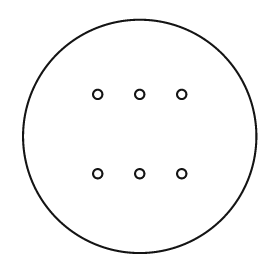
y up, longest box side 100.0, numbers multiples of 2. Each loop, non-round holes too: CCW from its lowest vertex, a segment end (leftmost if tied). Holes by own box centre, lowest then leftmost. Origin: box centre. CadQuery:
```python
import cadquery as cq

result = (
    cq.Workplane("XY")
    .moveTo(0.0, 0.0)
    .circle(50.0)
    .moveTo(-18.0, -16.0)
    .circle(2.0)
    .moveTo(0.0, -16.0)
    .circle(2.0)
    .moveTo(18.0, -16.0)
    .circle(2.0)
    .moveTo(-18.0, 18.0)
    .circle(2.0)
    .moveTo(0.0, 18.0)
    .circle(2.0)
    .moveTo(18.0, 18.0)
    .circle(2.0)
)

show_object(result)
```